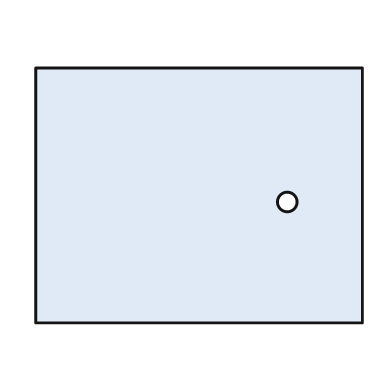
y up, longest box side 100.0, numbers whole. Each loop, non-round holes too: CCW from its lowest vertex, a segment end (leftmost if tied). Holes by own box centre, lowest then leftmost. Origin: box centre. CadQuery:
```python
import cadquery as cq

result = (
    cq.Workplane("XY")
    .moveTo(-50.0, -39.0)
    .lineTo(50.0, -39.0)
    .lineTo(50.0, 39.0)
    .lineTo(-50.0, 39.0)
    .close()
    .moveTo(27.0, -2.0)
    .circle(3.0)
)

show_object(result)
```